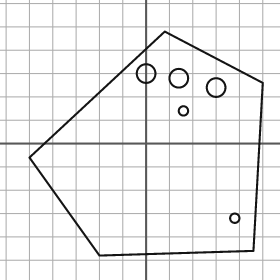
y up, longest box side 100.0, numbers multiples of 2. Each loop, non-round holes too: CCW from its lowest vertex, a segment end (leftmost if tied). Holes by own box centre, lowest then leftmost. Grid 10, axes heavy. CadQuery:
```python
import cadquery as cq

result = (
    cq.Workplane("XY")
    .moveTo(-20.0, -48.0)
    .lineTo(46.0, -46.0)
    .lineTo(50.0, 26.0)
    .lineTo(8.0, 48.0)
    .lineTo(-50.0, -6.0)
    .close()
    .moveTo(38.0, -32.0)
    .circle(2.0)
    .moveTo(16.0, 14.0)
    .circle(2.0)
    .moveTo(30.0, 24.0)
    .circle(4.0)
    .moveTo(14.0, 28.0)
    .circle(4.0)
    .moveTo(0.0, 30.0)
    .circle(4.0)
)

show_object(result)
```